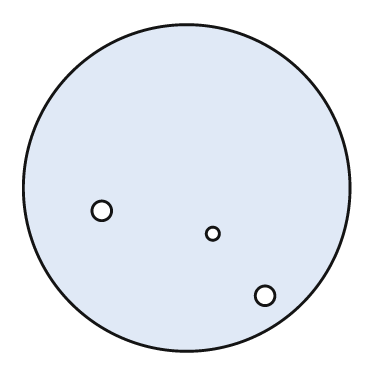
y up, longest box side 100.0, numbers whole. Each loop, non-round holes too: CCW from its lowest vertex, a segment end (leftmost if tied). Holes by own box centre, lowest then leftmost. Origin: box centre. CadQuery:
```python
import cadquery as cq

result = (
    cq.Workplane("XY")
    .moveTo(0.0, 0.0)
    .circle(50.0)
    .moveTo(24.0, -33.0)
    .circle(3.0)
    .moveTo(8.0, -14.0)
    .circle(2.0)
    .moveTo(-26.0, -7.0)
    .circle(3.0)
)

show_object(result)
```